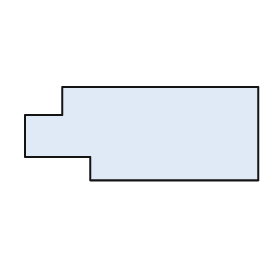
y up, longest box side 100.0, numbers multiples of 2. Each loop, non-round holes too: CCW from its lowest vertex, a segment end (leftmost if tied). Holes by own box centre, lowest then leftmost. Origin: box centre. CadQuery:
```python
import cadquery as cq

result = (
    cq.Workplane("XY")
    .moveTo(-22.0, -20.0)
    .lineTo(50.0, -20.0)
    .lineTo(50.0, 20.0)
    .lineTo(-34.0, 20.0)
    .lineTo(-34.0, 8.0)
    .lineTo(-50.0, 8.0)
    .lineTo(-50.0, -10.0)
    .lineTo(-22.0, -10.0)
    .close()
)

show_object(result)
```